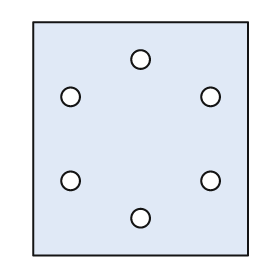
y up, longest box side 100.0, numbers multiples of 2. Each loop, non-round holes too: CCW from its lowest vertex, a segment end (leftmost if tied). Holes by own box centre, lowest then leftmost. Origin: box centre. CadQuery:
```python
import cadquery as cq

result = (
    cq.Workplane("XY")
    .moveTo(-46.0, -50.0)
    .lineTo(46.0, -50.0)
    .lineTo(46.0, 50.0)
    .lineTo(-46.0, 50.0)
    .close()
    .moveTo(0.0, -34.0)
    .circle(4.0)
    .moveTo(-30.0, -18.0)
    .circle(4.0)
    .moveTo(30.0, -18.0)
    .circle(4.0)
    .moveTo(-30.0, 18.0)
    .circle(4.0)
    .moveTo(30.0, 18.0)
    .circle(4.0)
    .moveTo(0.0, 34.0)
    .circle(4.0)
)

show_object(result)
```